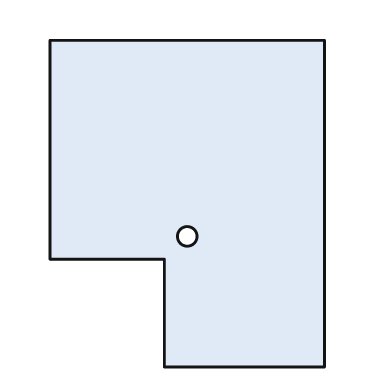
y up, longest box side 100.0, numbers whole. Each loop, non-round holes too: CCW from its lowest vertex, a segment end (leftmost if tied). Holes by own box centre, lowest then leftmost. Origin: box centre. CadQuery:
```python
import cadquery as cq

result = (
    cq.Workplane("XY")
    .moveTo(-7.0, -50.0)
    .lineTo(42.0, -50.0)
    .lineTo(42.0, 50.0)
    .lineTo(-42.0, 50.0)
    .lineTo(-42.0, -17.0)
    .lineTo(-7.0, -17.0)
    .close()
    .moveTo(0.0, -10.0)
    .circle(3.0)
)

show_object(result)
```